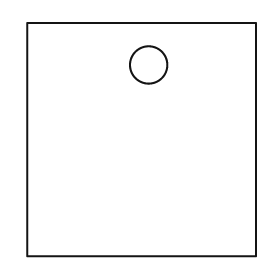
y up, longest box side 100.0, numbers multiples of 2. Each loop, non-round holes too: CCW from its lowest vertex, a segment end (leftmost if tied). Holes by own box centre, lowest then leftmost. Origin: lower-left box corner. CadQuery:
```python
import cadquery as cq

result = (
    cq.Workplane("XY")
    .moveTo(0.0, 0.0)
    .lineTo(98.0, 0.0)
    .lineTo(98.0, 100.0)
    .lineTo(0.0, 100.0)
    .close()
    .moveTo(52.0, 82.0)
    .circle(8.0)
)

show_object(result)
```